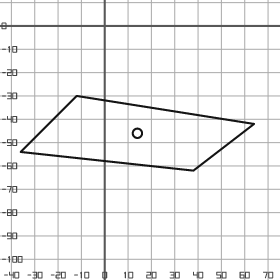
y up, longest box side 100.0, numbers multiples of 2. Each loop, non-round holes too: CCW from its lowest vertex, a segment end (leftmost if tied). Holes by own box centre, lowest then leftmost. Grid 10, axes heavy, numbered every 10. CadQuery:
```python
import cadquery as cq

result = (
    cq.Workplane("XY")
    .moveTo(38.0, -62.0)
    .lineTo(64.0, -42.0)
    .lineTo(-12.0, -30.0)
    .lineTo(-36.0, -54.0)
    .close()
    .moveTo(14.0, -46.0)
    .circle(2.0)
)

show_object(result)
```